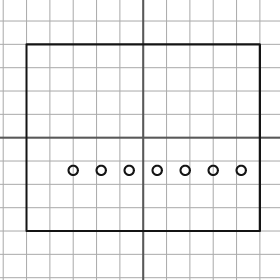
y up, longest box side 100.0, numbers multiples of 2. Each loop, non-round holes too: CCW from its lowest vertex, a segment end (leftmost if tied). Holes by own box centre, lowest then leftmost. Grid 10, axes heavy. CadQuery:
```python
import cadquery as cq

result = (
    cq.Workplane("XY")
    .moveTo(-50.0, -40.0)
    .lineTo(50.0, -40.0)
    .lineTo(50.0, 40.0)
    .lineTo(-50.0, 40.0)
    .close()
    .moveTo(-30.0, -14.0)
    .circle(2.0)
    .moveTo(-18.0, -14.0)
    .circle(2.0)
    .moveTo(-6.0, -14.0)
    .circle(2.0)
    .moveTo(6.0, -14.0)
    .circle(2.0)
    .moveTo(18.0, -14.0)
    .circle(2.0)
    .moveTo(30.0, -14.0)
    .circle(2.0)
    .moveTo(42.0, -14.0)
    .circle(2.0)
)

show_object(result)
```